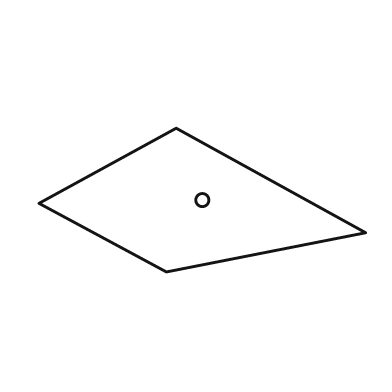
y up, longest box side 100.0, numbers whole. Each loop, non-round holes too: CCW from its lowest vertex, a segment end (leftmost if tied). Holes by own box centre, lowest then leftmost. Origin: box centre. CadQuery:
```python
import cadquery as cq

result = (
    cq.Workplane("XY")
    .moveTo(-11.0, -22.0)
    .lineTo(50.0, -10.0)
    .lineTo(-8.0, 22.0)
    .lineTo(-50.0, -1.0)
    .close()
    .moveTo(0.0, 0.0)
    .circle(2.0)
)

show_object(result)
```